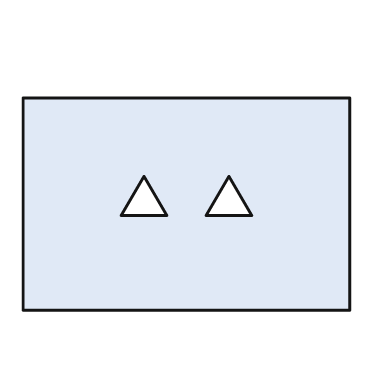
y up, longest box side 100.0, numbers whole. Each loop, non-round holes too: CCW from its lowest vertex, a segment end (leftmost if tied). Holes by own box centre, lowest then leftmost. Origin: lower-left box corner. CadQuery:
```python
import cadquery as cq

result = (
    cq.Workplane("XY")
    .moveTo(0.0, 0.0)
    .lineTo(100.0, 0.0)
    .lineTo(100.0, 65.0)
    .lineTo(0.0, 65.0)
    .close()
    .moveTo(30.0, 29.0)
    .lineTo(44.0, 29.0)
    .lineTo(37.0, 41.0)
    .close()
    .moveTo(56.0, 29.0)
    .lineTo(70.0, 29.0)
    .lineTo(63.0, 41.0)
    .close()
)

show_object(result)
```